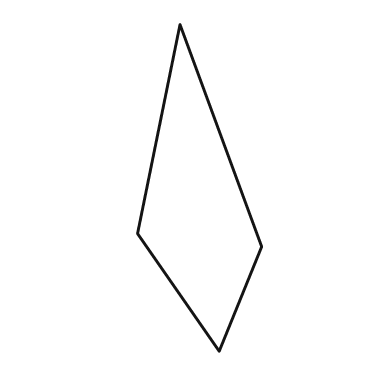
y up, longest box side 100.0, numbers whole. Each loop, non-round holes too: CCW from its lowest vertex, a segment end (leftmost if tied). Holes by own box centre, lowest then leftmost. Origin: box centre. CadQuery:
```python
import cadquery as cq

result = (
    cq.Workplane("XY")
    .moveTo(6.0, -50.0)
    .lineTo(19.0, -18.0)
    .lineTo(-6.0, 50.0)
    .lineTo(-19.0, -14.0)
    .close()
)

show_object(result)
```